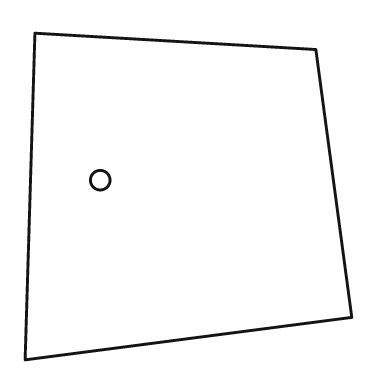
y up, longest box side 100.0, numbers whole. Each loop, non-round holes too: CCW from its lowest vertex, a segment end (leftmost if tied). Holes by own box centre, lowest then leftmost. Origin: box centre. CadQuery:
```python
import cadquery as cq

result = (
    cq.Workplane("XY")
    .moveTo(-50.0, -50.0)
    .lineTo(50.0, -37.0)
    .lineTo(39.0, 45.0)
    .lineTo(-47.0, 50.0)
    .close()
    .moveTo(-27.0, 5.0)
    .circle(3.0)
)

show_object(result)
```